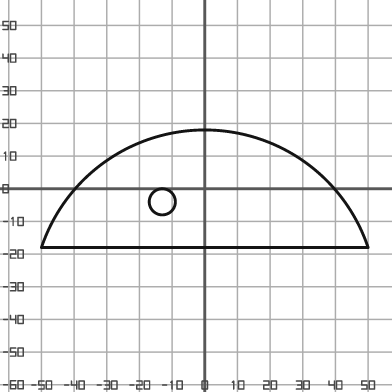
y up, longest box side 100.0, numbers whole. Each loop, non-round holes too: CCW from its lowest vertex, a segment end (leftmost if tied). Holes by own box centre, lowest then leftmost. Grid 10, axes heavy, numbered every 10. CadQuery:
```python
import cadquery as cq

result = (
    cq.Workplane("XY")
    .moveTo(-50.0, -18.0)
    .lineTo(50.0, -18.0)
    .threePointArc((0.0, 18.0), (-50.0, -18.0))
    .close()
    .moveTo(-13.0, -4.0)
    .circle(4.0)
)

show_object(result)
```